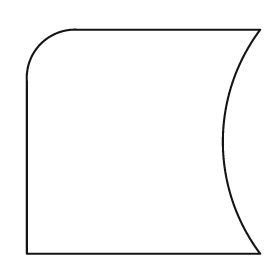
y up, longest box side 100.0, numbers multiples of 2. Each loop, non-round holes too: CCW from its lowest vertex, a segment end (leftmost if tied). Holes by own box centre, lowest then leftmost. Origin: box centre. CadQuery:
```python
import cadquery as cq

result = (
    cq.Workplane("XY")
    .moveTo(-50.0, -48.0)
    .lineTo(50.0, -48.0)
    .threePointArc((34.0, 0.0), (50.0, 48.0))
    .lineTo(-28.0, 48.0)
    .threePointArc((-44.0, 42.0), (-50.0, 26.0))
    .close()
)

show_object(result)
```